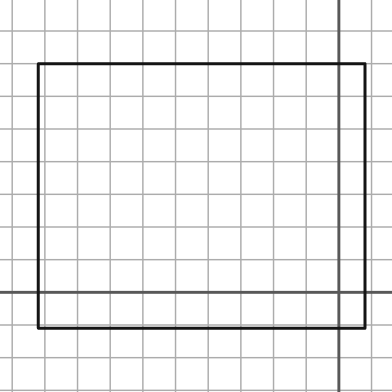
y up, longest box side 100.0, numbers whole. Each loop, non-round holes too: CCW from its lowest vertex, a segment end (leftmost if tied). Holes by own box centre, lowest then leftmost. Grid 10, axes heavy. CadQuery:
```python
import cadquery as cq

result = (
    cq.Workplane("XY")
    .moveTo(-92.0, -11.0)
    .lineTo(8.0, -11.0)
    .lineTo(8.0, 70.0)
    .lineTo(-92.0, 70.0)
    .close()
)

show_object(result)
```